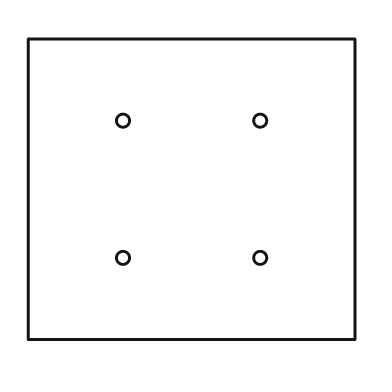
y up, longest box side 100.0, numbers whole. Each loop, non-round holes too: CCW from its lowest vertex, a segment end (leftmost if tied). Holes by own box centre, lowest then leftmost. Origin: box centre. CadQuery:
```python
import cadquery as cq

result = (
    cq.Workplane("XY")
    .moveTo(-50.0, -46.0)
    .lineTo(50.0, -46.0)
    .lineTo(50.0, 46.0)
    .lineTo(-50.0, 46.0)
    .close()
    .moveTo(-21.0, -21.0)
    .circle(2.0)
    .moveTo(21.0, -21.0)
    .circle(2.0)
    .moveTo(-21.0, 21.0)
    .circle(2.0)
    .moveTo(21.0, 21.0)
    .circle(2.0)
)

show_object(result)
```